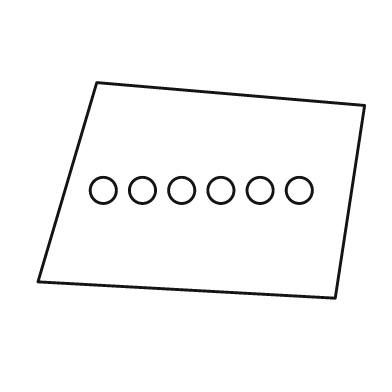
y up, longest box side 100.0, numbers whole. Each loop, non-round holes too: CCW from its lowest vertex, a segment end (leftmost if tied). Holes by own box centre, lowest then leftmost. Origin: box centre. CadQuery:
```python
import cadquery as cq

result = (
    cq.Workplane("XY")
    .moveTo(41.0, -33.0)
    .lineTo(50.0, 26.0)
    .lineTo(-32.0, 33.0)
    .lineTo(-50.0, -28.0)
    .close()
    .moveTo(-30.0, 0.0)
    .circle(4.0)
    .moveTo(-18.0, 0.0)
    .circle(4.0)
    .moveTo(-6.0, 0.0)
    .circle(4.0)
    .moveTo(6.0, 0.0)
    .circle(4.0)
    .moveTo(18.0, 0.0)
    .circle(4.0)
    .moveTo(30.0, 0.0)
    .circle(4.0)
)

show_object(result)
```